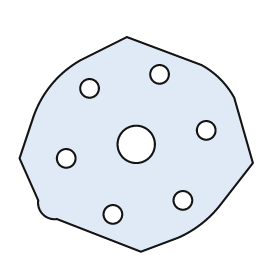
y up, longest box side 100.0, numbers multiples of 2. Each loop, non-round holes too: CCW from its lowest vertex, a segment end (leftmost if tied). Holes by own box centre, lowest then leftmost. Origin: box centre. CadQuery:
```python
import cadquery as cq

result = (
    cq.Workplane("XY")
    .moveTo(2.0, -46.0)
    .lineTo(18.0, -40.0)
    .threePointArc((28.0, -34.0), (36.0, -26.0))
    .lineTo(50.0, -8.0)
    .lineTo(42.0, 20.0)
    .threePointArc((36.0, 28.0), (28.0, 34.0))
    .lineTo(-4.0, 46.0)
    .lineTo(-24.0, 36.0)
    .threePointArc((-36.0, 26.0), (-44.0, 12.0))
    .lineTo(-50.0, -6.0)
    .lineTo(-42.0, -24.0)
    .threePointArc((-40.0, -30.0), (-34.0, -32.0))
    .close()
    .moveTo(-10.0, -30.0)
    .circle(4.0)
    .moveTo(20.0, -24.0)
    .circle(4.0)
    .moveTo(-30.0, -6.0)
    .circle(4.0)
    .moveTo(0.0, 0.0)
    .circle(8.0)
    .moveTo(30.0, 6.0)
    .circle(4.0)
    .moveTo(-20.0, 24.0)
    .circle(4.0)
    .moveTo(10.0, 30.0)
    .circle(4.0)
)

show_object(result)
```